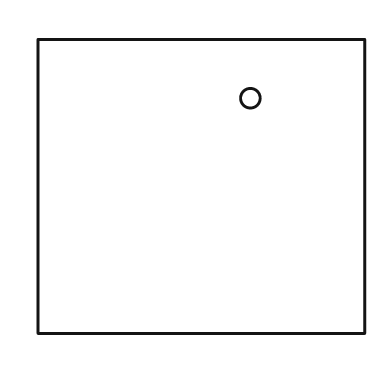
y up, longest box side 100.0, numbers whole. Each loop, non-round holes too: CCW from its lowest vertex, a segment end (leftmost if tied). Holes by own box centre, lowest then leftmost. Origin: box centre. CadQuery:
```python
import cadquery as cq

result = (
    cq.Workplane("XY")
    .moveTo(-50.0, -45.0)
    .lineTo(50.0, -45.0)
    .lineTo(50.0, 45.0)
    .lineTo(-50.0, 45.0)
    .close()
    .moveTo(15.0, 27.0)
    .circle(3.0)
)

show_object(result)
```